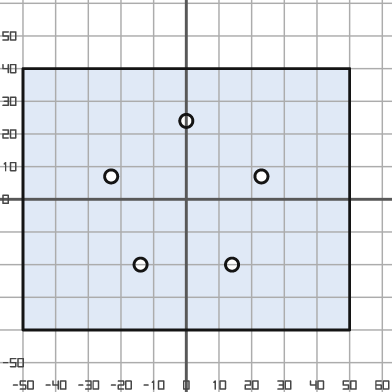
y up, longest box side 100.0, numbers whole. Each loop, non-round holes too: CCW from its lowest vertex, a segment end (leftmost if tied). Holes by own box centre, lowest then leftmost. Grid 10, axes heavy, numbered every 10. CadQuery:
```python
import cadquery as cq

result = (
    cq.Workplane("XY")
    .moveTo(-50.0, -40.0)
    .lineTo(50.0, -40.0)
    .lineTo(50.0, 40.0)
    .lineTo(-50.0, 40.0)
    .close()
    .moveTo(-14.0, -20.0)
    .circle(2.0)
    .moveTo(14.0, -20.0)
    .circle(2.0)
    .moveTo(-23.0, 7.0)
    .circle(2.0)
    .moveTo(23.0, 7.0)
    .circle(2.0)
    .moveTo(0.0, 24.0)
    .circle(2.0)
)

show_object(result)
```